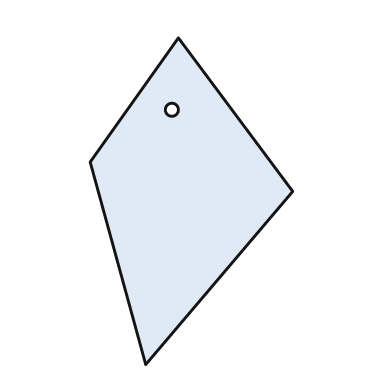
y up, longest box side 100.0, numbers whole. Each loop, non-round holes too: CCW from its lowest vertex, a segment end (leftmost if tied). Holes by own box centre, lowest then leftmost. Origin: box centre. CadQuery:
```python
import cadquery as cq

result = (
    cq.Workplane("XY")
    .moveTo(-14.0, -50.0)
    .lineTo(31.0, 3.0)
    .lineTo(-4.0, 50.0)
    .lineTo(-31.0, 12.0)
    .close()
    .moveTo(-6.0, 28.0)
    .circle(2.0)
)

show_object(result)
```